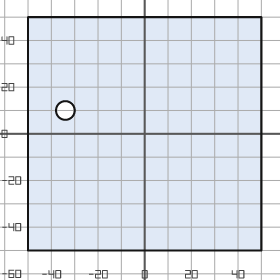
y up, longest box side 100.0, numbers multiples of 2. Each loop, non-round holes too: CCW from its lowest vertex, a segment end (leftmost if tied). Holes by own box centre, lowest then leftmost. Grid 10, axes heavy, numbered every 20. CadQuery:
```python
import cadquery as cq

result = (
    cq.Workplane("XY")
    .moveTo(-50.0, -50.0)
    .lineTo(50.0, -50.0)
    .lineTo(50.0, 50.0)
    .lineTo(-50.0, 50.0)
    .close()
    .moveTo(-34.0, 10.0)
    .circle(4.0)
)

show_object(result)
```